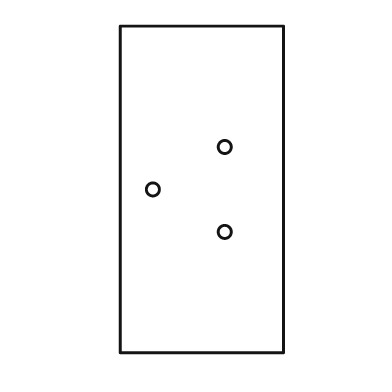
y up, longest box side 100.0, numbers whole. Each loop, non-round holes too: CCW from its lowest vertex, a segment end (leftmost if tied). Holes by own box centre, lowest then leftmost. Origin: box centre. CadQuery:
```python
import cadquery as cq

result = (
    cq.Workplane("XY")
    .moveTo(-25.0, -50.0)
    .lineTo(25.0, -50.0)
    .lineTo(25.0, 50.0)
    .lineTo(-25.0, 50.0)
    .close()
    .moveTo(7.0, -13.0)
    .circle(2.0)
    .moveTo(-15.0, 0.0)
    .circle(2.0)
    .moveTo(7.0, 13.0)
    .circle(2.0)
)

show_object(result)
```